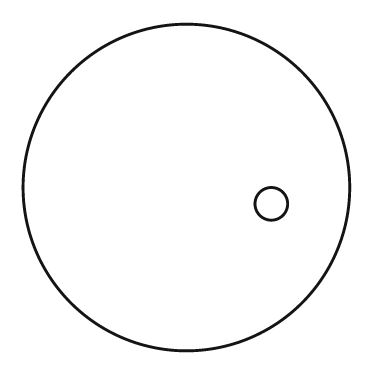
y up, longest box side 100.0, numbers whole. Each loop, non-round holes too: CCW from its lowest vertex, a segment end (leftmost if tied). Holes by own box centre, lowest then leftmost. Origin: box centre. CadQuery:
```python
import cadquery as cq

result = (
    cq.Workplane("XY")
    .moveTo(0.0, 0.0)
    .circle(50.0)
    .moveTo(26.0, -5.0)
    .circle(5.0)
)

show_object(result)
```